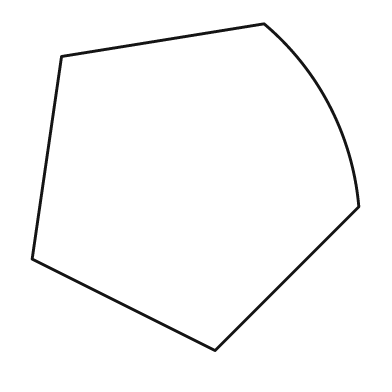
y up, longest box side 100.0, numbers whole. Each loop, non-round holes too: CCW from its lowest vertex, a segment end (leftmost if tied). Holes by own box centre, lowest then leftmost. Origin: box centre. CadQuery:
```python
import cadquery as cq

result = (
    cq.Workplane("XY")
    .moveTo(6.0, -50.0)
    .lineTo(50.0, -6.0)
    .threePointArc((41.0, 25.0), (21.0, 50.0))
    .lineTo(-41.0, 40.0)
    .lineTo(-50.0, -22.0)
    .close()
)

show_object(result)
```